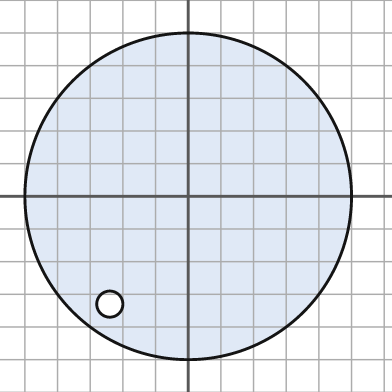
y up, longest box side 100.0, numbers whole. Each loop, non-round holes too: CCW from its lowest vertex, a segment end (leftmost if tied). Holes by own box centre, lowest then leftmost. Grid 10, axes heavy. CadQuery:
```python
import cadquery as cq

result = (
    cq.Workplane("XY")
    .moveTo(0.0, 0.0)
    .circle(50.0)
    .moveTo(-24.0, -33.0)
    .circle(4.0)
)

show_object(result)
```